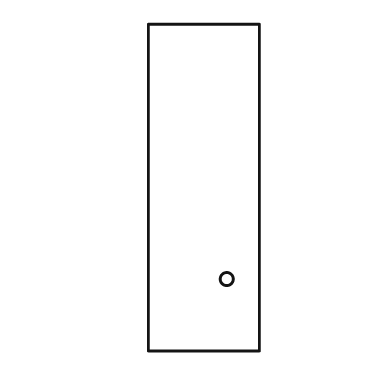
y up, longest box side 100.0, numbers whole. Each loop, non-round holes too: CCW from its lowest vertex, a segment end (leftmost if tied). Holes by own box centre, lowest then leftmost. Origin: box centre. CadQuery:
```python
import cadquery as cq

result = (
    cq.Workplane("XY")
    .moveTo(-17.0, -50.0)
    .lineTo(17.0, -50.0)
    .lineTo(17.0, 50.0)
    .lineTo(-17.0, 50.0)
    .close()
    .moveTo(7.0, -28.0)
    .circle(2.0)
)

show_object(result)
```